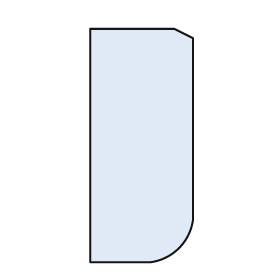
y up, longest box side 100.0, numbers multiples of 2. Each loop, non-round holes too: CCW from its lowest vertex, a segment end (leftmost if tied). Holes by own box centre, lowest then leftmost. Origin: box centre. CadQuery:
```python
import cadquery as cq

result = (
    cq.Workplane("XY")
    .moveTo(-22.0, -50.0)
    .lineTo(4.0, -50.0)
    .threePointArc((16.0, -44.0), (22.0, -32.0))
    .lineTo(22.0, 46.0)
    .lineTo(14.0, 50.0)
    .lineTo(-22.0, 50.0)
    .close()
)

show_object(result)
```